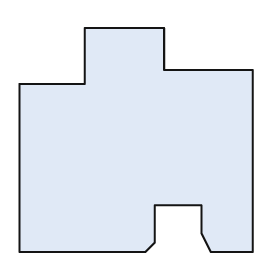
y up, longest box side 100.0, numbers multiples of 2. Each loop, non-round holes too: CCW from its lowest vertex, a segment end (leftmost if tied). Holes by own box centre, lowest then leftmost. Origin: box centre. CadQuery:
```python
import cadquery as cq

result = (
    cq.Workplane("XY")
    .moveTo(-50.0, -48.0)
    .lineTo(4.0, -48.0)
    .lineTo(8.0, -44.0)
    .lineTo(8.0, -28.0)
    .lineTo(28.0, -28.0)
    .lineTo(28.0, -40.0)
    .lineTo(32.0, -48.0)
    .lineTo(50.0, -48.0)
    .lineTo(50.0, 30.0)
    .lineTo(12.0, 30.0)
    .lineTo(12.0, 48.0)
    .lineTo(-22.0, 48.0)
    .lineTo(-22.0, 24.0)
    .lineTo(-50.0, 24.0)
    .close()
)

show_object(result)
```